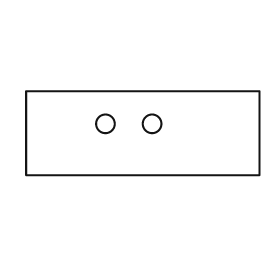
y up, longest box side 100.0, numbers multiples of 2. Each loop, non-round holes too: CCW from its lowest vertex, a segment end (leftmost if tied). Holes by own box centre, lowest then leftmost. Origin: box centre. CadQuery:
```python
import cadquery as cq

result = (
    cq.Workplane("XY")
    .moveTo(-50.0, -18.0)
    .lineTo(50.0, -18.0)
    .lineTo(50.0, 18.0)
    .lineTo(-50.0, 18.0)
    .close()
    .moveTo(-16.0, 4.0)
    .circle(4.0)
    .moveTo(4.0, 4.0)
    .circle(4.0)
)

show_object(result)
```